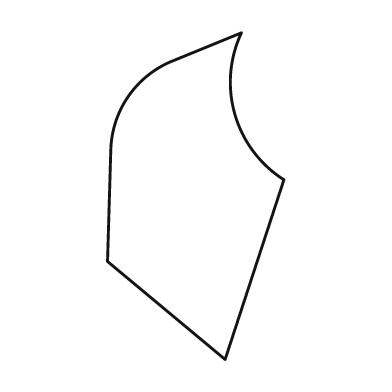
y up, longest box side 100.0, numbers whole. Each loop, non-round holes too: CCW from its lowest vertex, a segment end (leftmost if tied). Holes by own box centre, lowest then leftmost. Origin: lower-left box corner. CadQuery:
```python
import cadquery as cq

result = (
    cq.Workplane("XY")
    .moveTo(36.0, 0.0)
    .lineTo(54.0, 55.0)
    .threePointArc((39.0, 75.0), (41.0, 100.0))
    .lineTo(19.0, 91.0)
    .threePointArc((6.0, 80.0), (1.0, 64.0))
    .lineTo(0.0, 30.0)
    .close()
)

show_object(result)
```